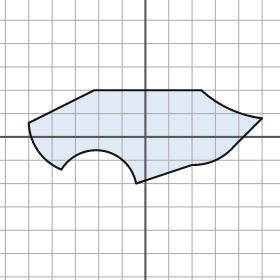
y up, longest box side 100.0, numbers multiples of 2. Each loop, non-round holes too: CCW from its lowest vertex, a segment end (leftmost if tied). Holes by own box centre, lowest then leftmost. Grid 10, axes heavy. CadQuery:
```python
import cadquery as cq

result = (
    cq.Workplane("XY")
    .moveTo(-4.0, -20.0)
    .lineTo(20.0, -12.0)
    .threePointArc((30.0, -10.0), (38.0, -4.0))
    .lineTo(50.0, 8.0)
    .threePointArc((36.0, 12.0), (24.0, 20.0))
    .lineTo(-22.0, 20.0)
    .lineTo(-50.0, 6.0)
    .threePointArc((-46.0, -6.0), (-36.0, -14.0))
    .threePointArc((-18.0, -6.0), (-4.0, -20.0))
    .close()
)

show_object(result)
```